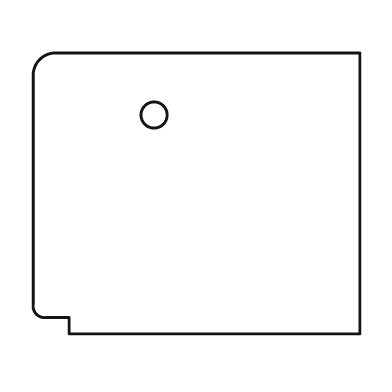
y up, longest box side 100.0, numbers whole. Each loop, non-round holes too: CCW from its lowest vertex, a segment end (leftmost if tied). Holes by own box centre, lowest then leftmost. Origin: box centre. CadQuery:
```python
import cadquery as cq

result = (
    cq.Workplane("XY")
    .moveTo(-39.0, -43.0)
    .lineTo(50.0, -43.0)
    .lineTo(50.0, 43.0)
    .lineTo(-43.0, 43.0)
    .threePointArc((-48.0, 41.0), (-50.0, 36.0))
    .lineTo(-50.0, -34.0)
    .threePointArc((-49.0, -37.0), (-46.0, -38.0))
    .lineTo(-39.0, -38.0)
    .close()
    .moveTo(-13.0, 24.0)
    .circle(4.0)
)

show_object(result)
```